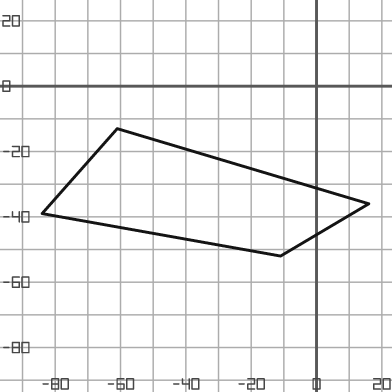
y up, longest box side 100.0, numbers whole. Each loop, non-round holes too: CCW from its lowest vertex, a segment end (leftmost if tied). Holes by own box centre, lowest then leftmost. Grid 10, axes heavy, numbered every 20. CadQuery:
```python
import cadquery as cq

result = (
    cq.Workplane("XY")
    .moveTo(-11.0, -52.0)
    .lineTo(16.0, -36.0)
    .lineTo(-61.0, -13.0)
    .lineTo(-84.0, -39.0)
    .close()
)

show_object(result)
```